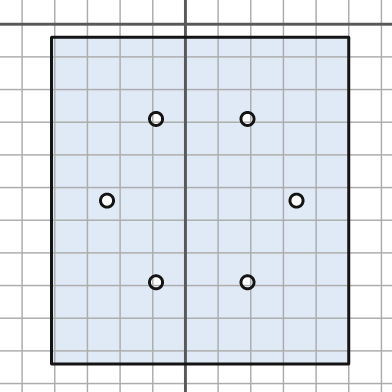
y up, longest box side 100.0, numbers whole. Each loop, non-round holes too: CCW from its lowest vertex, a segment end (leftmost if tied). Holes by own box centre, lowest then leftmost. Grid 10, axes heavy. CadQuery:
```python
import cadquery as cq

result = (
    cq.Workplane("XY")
    .moveTo(-41.0, -104.0)
    .lineTo(50.0, -104.0)
    .lineTo(50.0, -4.0)
    .lineTo(-41.0, -4.0)
    .close()
    .moveTo(-9.0, -79.0)
    .circle(2.0)
    .moveTo(19.0, -79.0)
    .circle(2.0)
    .moveTo(-24.0, -54.0)
    .circle(2.0)
    .moveTo(34.0, -54.0)
    .circle(2.0)
    .moveTo(-9.0, -29.0)
    .circle(2.0)
    .moveTo(19.0, -29.0)
    .circle(2.0)
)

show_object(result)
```